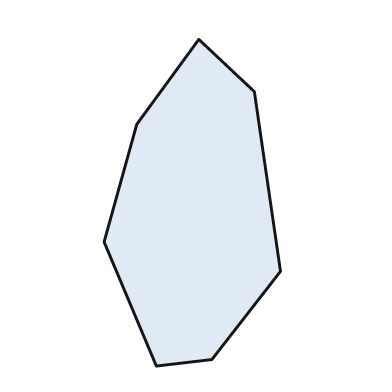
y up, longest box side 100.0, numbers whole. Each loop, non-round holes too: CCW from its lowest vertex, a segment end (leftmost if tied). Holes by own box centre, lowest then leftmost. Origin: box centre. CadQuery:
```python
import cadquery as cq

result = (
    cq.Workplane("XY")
    .moveTo(-11.0, -50.0)
    .lineTo(6.0, -48.0)
    .lineTo(27.0, -21.0)
    .lineTo(19.0, 34.0)
    .lineTo(2.0, 50.0)
    .lineTo(-17.0, 24.0)
    .lineTo(-27.0, -12.0)
    .close()
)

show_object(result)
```